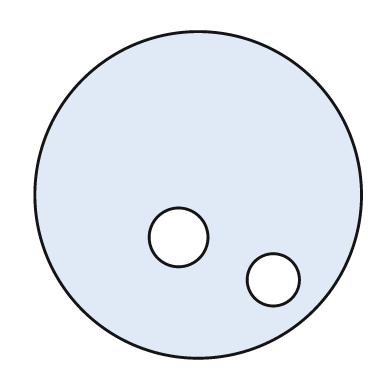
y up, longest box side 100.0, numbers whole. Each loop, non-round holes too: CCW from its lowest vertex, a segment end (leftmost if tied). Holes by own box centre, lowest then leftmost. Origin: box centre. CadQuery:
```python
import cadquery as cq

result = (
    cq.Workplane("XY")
    .moveTo(0.0, 0.0)
    .circle(50.0)
    .moveTo(23.0, -26.0)
    .circle(8.0)
    .moveTo(-6.0, -13.0)
    .circle(9.0)
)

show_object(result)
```